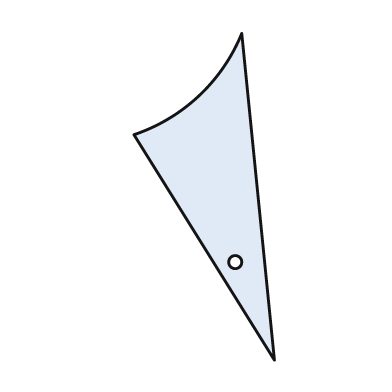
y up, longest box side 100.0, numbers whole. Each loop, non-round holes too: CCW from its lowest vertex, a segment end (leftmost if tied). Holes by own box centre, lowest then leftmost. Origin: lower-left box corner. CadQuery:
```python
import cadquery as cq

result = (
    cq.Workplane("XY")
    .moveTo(43.0, 0.0)
    .lineTo(33.0, 100.0)
    .threePointArc((20.0, 81.0), (0.0, 69.0))
    .close()
    .moveTo(31.0, 30.0)
    .circle(2.0)
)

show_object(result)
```